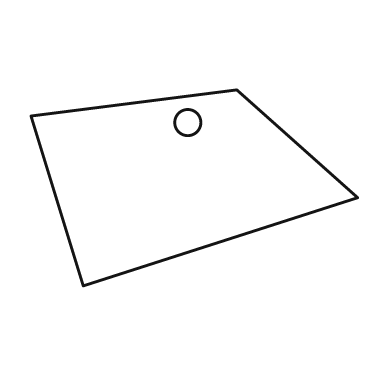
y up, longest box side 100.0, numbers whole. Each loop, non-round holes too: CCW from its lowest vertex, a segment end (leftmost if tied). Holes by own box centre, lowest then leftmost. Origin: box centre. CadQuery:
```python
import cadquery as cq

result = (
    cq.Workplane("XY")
    .moveTo(-34.0, -30.0)
    .lineTo(50.0, -3.0)
    .lineTo(13.0, 30.0)
    .lineTo(-50.0, 22.0)
    .close()
    .moveTo(-2.0, 20.0)
    .circle(4.0)
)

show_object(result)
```